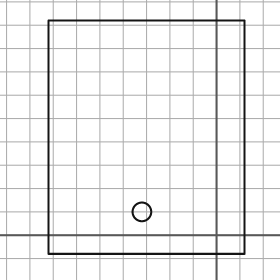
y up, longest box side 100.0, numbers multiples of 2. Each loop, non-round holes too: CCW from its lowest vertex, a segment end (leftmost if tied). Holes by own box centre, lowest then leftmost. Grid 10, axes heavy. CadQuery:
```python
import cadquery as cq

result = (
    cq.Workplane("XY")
    .moveTo(-72.0, -8.0)
    .lineTo(12.0, -8.0)
    .lineTo(12.0, 92.0)
    .lineTo(-72.0, 92.0)
    .close()
    .moveTo(-32.0, 10.0)
    .circle(4.0)
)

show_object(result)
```